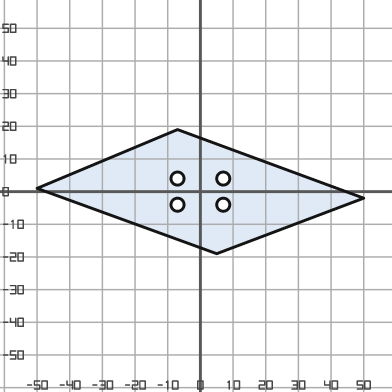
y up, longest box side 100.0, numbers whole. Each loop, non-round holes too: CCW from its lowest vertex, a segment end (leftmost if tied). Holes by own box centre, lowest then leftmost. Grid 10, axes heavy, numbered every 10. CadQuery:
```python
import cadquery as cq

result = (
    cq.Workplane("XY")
    .moveTo(5.0, -19.0)
    .lineTo(50.0, -2.0)
    .lineTo(-7.0, 19.0)
    .lineTo(-50.0, 1.0)
    .close()
    .moveTo(-7.0, -4.0)
    .circle(2.0)
    .moveTo(7.0, -4.0)
    .circle(2.0)
    .moveTo(-7.0, 4.0)
    .circle(2.0)
    .moveTo(7.0, 4.0)
    .circle(2.0)
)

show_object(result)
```